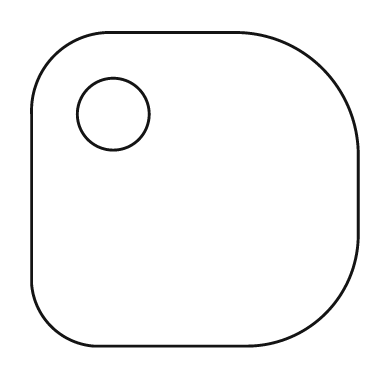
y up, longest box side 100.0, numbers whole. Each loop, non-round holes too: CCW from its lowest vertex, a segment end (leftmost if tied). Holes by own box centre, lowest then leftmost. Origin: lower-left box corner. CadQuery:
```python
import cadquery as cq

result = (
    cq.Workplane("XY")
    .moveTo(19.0, 0.0)
    .lineTo(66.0, 0.0)
    .threePointArc((90.0, 10.0), (100.0, 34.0))
    .lineTo(100.0, 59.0)
    .threePointArc((89.0, 85.0), (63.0, 96.0))
    .lineTo(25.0, 96.0)
    .threePointArc((7.0, 89.0), (0.0, 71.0))
    .lineTo(0.0, 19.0)
    .threePointArc((6.0, 6.0), (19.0, 0.0))
    .close()
    .moveTo(25.0, 71.0)
    .circle(11.0)
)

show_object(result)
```